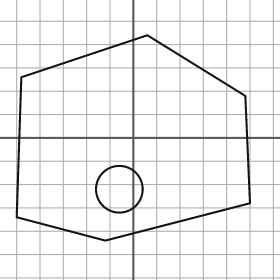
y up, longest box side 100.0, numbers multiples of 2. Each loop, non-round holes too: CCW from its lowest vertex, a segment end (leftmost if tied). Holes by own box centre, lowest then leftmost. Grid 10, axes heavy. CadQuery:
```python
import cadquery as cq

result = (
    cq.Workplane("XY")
    .moveTo(-12.0, -44.0)
    .lineTo(50.0, -28.0)
    .lineTo(48.0, 18.0)
    .lineTo(6.0, 44.0)
    .lineTo(-48.0, 26.0)
    .lineTo(-50.0, -34.0)
    .close()
    .moveTo(-6.0, -22.0)
    .circle(10.0)
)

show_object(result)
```